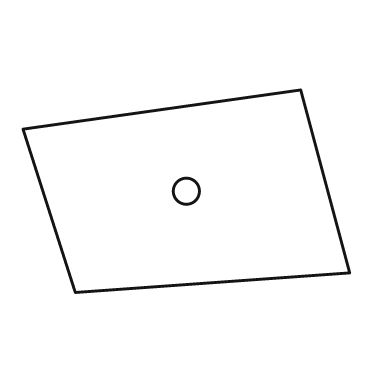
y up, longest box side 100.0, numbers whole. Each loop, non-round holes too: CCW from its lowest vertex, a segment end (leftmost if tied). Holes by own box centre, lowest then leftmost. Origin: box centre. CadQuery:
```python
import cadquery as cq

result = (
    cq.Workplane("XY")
    .moveTo(-34.0, -31.0)
    .lineTo(50.0, -25.0)
    .lineTo(35.0, 31.0)
    .lineTo(-50.0, 19.0)
    .close()
    .moveTo(0.0, 0.0)
    .circle(4.0)
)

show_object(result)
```